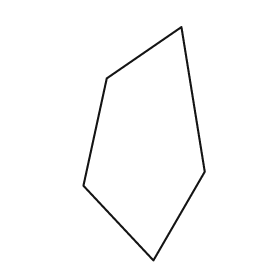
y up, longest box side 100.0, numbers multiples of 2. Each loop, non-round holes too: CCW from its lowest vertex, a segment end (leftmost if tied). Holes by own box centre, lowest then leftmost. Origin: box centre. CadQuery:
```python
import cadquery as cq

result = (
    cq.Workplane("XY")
    .moveTo(4.0, -50.0)
    .lineTo(26.0, -12.0)
    .lineTo(16.0, 50.0)
    .lineTo(-16.0, 28.0)
    .lineTo(-26.0, -18.0)
    .close()
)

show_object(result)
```